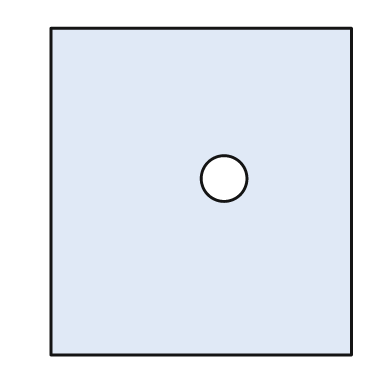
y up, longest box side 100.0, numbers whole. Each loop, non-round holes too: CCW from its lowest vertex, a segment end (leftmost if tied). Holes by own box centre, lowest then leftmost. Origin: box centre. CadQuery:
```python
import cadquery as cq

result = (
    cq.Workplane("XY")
    .moveTo(-46.0, -50.0)
    .lineTo(46.0, -50.0)
    .lineTo(46.0, 50.0)
    .lineTo(-46.0, 50.0)
    .close()
    .moveTo(7.0, 4.0)
    .circle(7.0)
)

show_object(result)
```